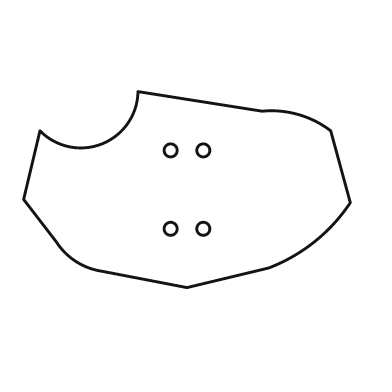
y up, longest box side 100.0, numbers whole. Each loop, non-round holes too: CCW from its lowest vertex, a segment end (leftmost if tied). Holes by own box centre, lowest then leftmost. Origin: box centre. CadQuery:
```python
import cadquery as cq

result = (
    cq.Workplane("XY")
    .moveTo(0.0, -30.0)
    .lineTo(25.0, -24.0)
    .threePointArc((39.0, -16.0), (50.0, -4.0))
    .lineTo(44.0, 18.0)
    .threePointArc((34.0, 23.0), (23.0, 24.0))
    .lineTo(-15.0, 30.0)
    .threePointArc((-26.0, 14.0), (-45.0, 18.0))
    .lineTo(-50.0, -3.0)
    .lineTo(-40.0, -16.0)
    .threePointArc((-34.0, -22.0), (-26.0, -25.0))
    .close()
    .moveTo(-5.0, -12.0)
    .circle(2.0)
    .moveTo(5.0, -12.0)
    .circle(2.0)
    .moveTo(-5.0, 12.0)
    .circle(2.0)
    .moveTo(5.0, 12.0)
    .circle(2.0)
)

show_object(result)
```